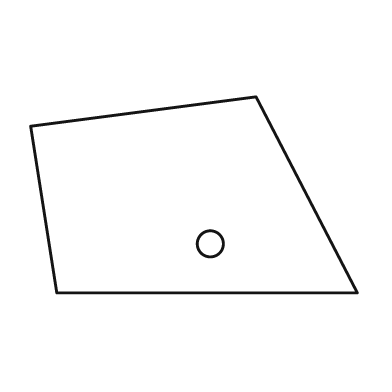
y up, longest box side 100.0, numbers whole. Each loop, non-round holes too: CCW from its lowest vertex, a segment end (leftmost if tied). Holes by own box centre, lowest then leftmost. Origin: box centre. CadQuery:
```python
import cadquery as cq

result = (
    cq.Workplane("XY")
    .moveTo(-42.0, -30.0)
    .lineTo(50.0, -30.0)
    .lineTo(19.0, 30.0)
    .lineTo(-50.0, 21.0)
    .close()
    .moveTo(5.0, -15.0)
    .circle(4.0)
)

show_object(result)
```